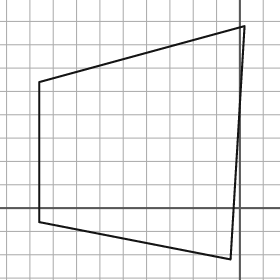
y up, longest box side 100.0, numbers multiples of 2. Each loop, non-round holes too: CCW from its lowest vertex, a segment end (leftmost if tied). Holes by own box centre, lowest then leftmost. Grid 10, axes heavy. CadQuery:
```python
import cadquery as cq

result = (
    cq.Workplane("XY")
    .moveTo(-4.0, -22.0)
    .lineTo(2.0, 78.0)
    .lineTo(-86.0, 54.0)
    .lineTo(-86.0, -6.0)
    .close()
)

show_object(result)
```